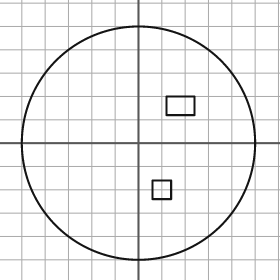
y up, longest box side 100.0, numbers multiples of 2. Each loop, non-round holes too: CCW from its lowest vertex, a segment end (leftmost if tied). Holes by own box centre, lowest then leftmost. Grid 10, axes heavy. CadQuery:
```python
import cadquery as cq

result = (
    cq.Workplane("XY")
    .moveTo(0.0, 0.0)
    .circle(50.0)
    .moveTo(6.0, -24.0)
    .lineTo(14.0, -24.0)
    .lineTo(14.0, -16.0)
    .lineTo(6.0, -16.0)
    .close()
    .moveTo(12.0, 12.0)
    .lineTo(24.0, 12.0)
    .lineTo(24.0, 20.0)
    .lineTo(12.0, 20.0)
    .close()
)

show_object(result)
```